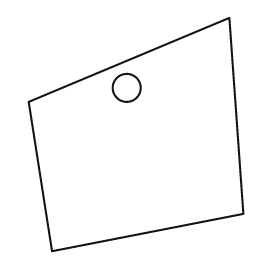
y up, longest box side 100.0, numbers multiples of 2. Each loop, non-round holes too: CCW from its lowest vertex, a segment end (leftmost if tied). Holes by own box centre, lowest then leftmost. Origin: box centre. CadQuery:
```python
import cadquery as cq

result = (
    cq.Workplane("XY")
    .moveTo(-36.0, -50.0)
    .lineTo(46.0, -34.0)
    .lineTo(40.0, 50.0)
    .lineTo(-46.0, 14.0)
    .close()
    .moveTo(-4.0, 20.0)
    .circle(6.0)
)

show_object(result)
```